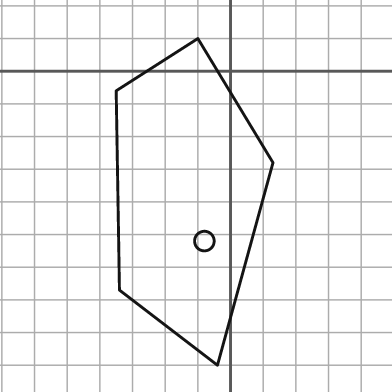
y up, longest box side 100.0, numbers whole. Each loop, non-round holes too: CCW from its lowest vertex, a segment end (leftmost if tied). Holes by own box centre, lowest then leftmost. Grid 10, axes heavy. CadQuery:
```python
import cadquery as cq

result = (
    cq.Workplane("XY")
    .moveTo(-4.0, -90.0)
    .lineTo(13.0, -28.0)
    .lineTo(-10.0, 10.0)
    .lineTo(-35.0, -6.0)
    .lineTo(-34.0, -67.0)
    .close()
    .moveTo(-8.0, -52.0)
    .circle(3.0)
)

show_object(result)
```